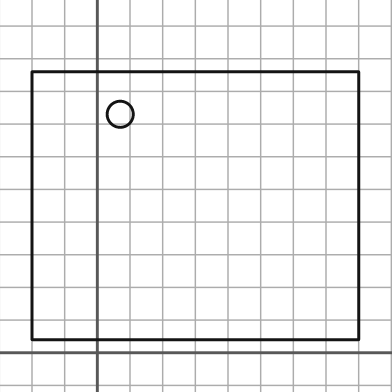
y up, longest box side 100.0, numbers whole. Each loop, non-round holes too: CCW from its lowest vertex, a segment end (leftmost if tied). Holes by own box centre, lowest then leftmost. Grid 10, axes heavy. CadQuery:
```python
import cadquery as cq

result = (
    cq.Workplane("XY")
    .moveTo(-20.0, 4.0)
    .lineTo(80.0, 4.0)
    .lineTo(80.0, 86.0)
    .lineTo(-20.0, 86.0)
    .close()
    .moveTo(7.0, 73.0)
    .circle(4.0)
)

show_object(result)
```